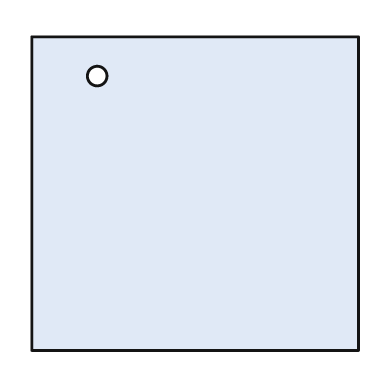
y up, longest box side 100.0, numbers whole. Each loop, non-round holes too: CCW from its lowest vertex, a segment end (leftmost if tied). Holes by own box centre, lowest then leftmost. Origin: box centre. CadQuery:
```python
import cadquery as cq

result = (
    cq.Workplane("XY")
    .moveTo(-50.0, -48.0)
    .lineTo(50.0, -48.0)
    .lineTo(50.0, 48.0)
    .lineTo(-50.0, 48.0)
    .close()
    .moveTo(-30.0, 36.0)
    .circle(3.0)
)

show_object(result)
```